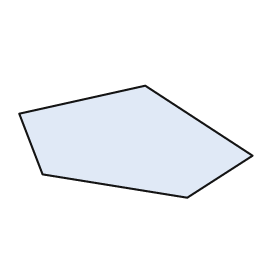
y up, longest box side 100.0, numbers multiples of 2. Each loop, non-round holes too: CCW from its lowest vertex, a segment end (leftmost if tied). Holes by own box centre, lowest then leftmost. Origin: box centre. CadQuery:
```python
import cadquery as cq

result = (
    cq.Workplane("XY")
    .moveTo(22.0, -24.0)
    .lineTo(50.0, -6.0)
    .lineTo(4.0, 24.0)
    .lineTo(-50.0, 12.0)
    .lineTo(-40.0, -14.0)
    .close()
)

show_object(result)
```